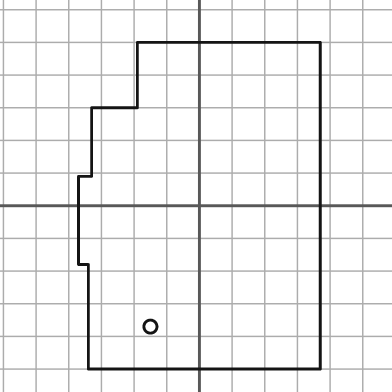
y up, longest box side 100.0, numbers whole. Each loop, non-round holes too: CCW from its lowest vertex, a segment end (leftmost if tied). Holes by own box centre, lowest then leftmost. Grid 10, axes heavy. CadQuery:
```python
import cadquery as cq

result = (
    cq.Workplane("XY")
    .moveTo(-34.0, -50.0)
    .lineTo(37.0, -50.0)
    .lineTo(37.0, 50.0)
    .lineTo(-19.0, 50.0)
    .lineTo(-19.0, 30.0)
    .lineTo(-33.0, 30.0)
    .lineTo(-33.0, 9.0)
    .lineTo(-37.0, 9.0)
    .lineTo(-37.0, -18.0)
    .lineTo(-34.0, -18.0)
    .close()
    .moveTo(-15.0, -37.0)
    .circle(2.0)
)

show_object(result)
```